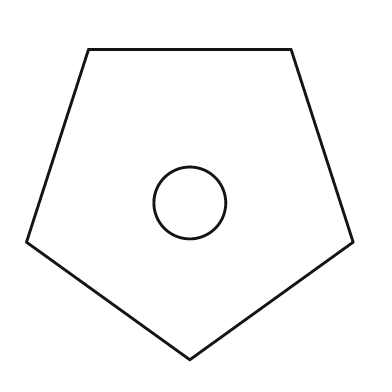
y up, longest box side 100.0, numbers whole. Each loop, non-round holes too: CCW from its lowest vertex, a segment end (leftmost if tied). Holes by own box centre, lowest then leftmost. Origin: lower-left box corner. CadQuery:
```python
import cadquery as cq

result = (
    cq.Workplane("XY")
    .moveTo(50.0, 0.0)
    .lineTo(100.0, 36.0)
    .lineTo(81.0, 95.0)
    .lineTo(19.0, 95.0)
    .lineTo(0.0, 36.0)
    .close()
    .moveTo(50.0, 48.0)
    .circle(11.0)
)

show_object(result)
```